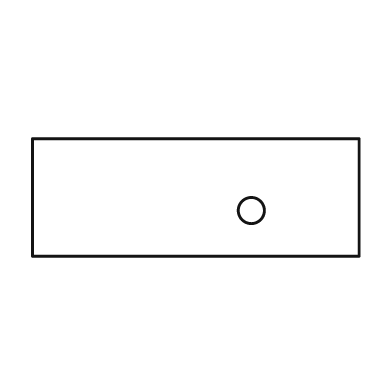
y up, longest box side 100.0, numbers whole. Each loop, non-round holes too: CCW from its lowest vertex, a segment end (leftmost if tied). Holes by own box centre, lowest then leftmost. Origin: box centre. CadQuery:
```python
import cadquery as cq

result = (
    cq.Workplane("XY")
    .moveTo(-50.0, -18.0)
    .lineTo(50.0, -18.0)
    .lineTo(50.0, 18.0)
    .lineTo(-50.0, 18.0)
    .close()
    .moveTo(17.0, -4.0)
    .circle(4.0)
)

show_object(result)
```